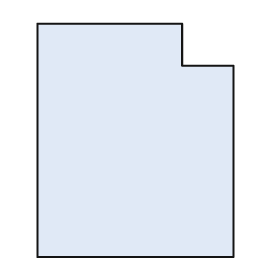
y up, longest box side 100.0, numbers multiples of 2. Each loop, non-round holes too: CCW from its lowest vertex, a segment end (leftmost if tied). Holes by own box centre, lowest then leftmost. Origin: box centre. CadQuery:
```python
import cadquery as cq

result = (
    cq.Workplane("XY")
    .moveTo(-42.0, -50.0)
    .lineTo(42.0, -50.0)
    .lineTo(42.0, 32.0)
    .lineTo(20.0, 32.0)
    .lineTo(20.0, 50.0)
    .lineTo(-42.0, 50.0)
    .close()
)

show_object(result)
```